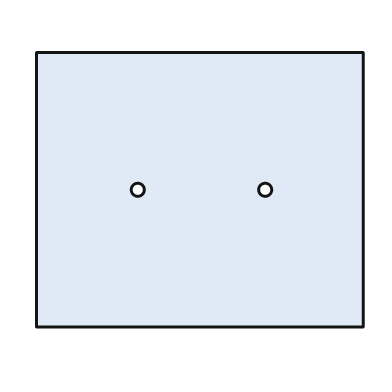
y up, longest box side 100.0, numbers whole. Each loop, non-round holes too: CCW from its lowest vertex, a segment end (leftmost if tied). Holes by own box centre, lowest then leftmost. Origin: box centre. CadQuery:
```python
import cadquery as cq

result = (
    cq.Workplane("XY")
    .moveTo(-50.0, -42.0)
    .lineTo(50.0, -42.0)
    .lineTo(50.0, 42.0)
    .lineTo(-50.0, 42.0)
    .close()
    .moveTo(-19.0, 0.0)
    .circle(2.0)
    .moveTo(20.0, 0.0)
    .circle(2.0)
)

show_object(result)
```